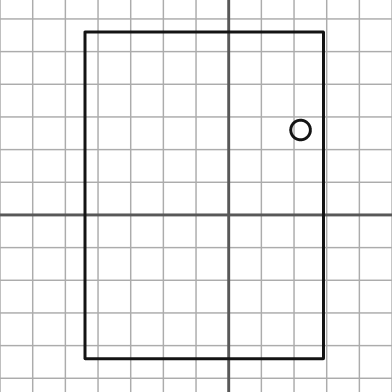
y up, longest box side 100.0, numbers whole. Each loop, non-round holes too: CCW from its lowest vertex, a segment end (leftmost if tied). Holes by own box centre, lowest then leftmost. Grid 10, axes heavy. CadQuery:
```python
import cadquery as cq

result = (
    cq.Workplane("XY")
    .moveTo(-44.0, -44.0)
    .lineTo(29.0, -44.0)
    .lineTo(29.0, 56.0)
    .lineTo(-44.0, 56.0)
    .close()
    .moveTo(22.0, 26.0)
    .circle(3.0)
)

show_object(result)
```